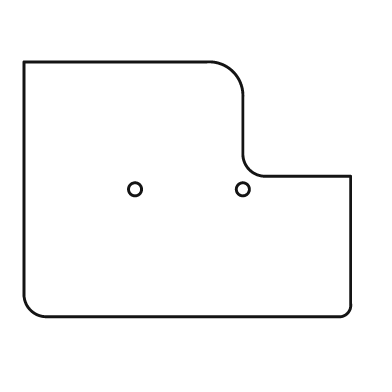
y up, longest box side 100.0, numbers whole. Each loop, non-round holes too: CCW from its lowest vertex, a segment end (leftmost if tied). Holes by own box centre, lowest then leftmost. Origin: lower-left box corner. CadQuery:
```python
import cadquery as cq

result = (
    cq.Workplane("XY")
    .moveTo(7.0, 0.0)
    .lineTo(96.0, 0.0)
    .threePointArc((99.0, 1.0), (100.0, 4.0))
    .lineTo(100.0, 43.0)
    .lineTo(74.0, 43.0)
    .threePointArc((69.0, 45.0), (67.0, 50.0))
    .lineTo(67.0, 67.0)
    .threePointArc((64.0, 75.0), (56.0, 78.0))
    .lineTo(0.0, 78.0)
    .lineTo(0.0, 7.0)
    .threePointArc((2.0, 2.0), (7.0, 0.0))
    .close()
    .moveTo(34.0, 39.0)
    .circle(2.0)
    .moveTo(67.0, 39.0)
    .circle(2.0)
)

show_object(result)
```